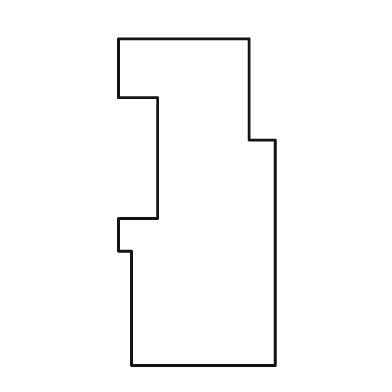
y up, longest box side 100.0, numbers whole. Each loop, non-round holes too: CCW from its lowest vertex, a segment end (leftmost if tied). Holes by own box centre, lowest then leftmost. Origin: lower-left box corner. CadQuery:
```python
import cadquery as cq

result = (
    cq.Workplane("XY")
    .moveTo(4.0, 0.0)
    .lineTo(48.0, 0.0)
    .lineTo(48.0, 69.0)
    .lineTo(40.0, 69.0)
    .lineTo(40.0, 100.0)
    .lineTo(0.0, 100.0)
    .lineTo(0.0, 82.0)
    .lineTo(12.0, 82.0)
    .lineTo(12.0, 45.0)
    .lineTo(0.0, 45.0)
    .lineTo(0.0, 35.0)
    .lineTo(4.0, 35.0)
    .close()
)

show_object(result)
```